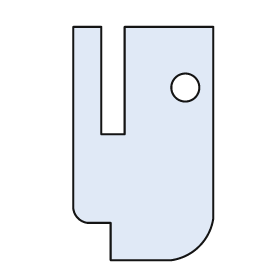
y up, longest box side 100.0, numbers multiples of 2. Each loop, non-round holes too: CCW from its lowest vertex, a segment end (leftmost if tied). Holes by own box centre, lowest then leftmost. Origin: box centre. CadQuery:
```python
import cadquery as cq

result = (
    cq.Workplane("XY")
    .moveTo(-14.0, -50.0)
    .lineTo(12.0, -50.0)
    .threePointArc((24.0, -44.0), (30.0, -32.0))
    .lineTo(30.0, 50.0)
    .lineTo(-8.0, 50.0)
    .lineTo(-8.0, 4.0)
    .lineTo(-18.0, 4.0)
    .lineTo(-18.0, 50.0)
    .lineTo(-30.0, 50.0)
    .lineTo(-30.0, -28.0)
    .threePointArc((-28.0, -32.0), (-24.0, -34.0))
    .lineTo(-14.0, -34.0)
    .close()
    .moveTo(18.0, 24.0)
    .circle(6.0)
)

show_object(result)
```